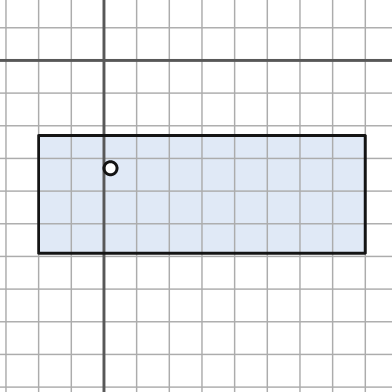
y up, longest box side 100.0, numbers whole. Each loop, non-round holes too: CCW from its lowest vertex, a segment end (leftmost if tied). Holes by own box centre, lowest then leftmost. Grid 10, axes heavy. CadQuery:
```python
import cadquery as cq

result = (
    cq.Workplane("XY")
    .moveTo(-20.0, -59.0)
    .lineTo(80.0, -59.0)
    .lineTo(80.0, -23.0)
    .lineTo(-20.0, -23.0)
    .close()
    .moveTo(2.0, -33.0)
    .circle(2.0)
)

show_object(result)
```